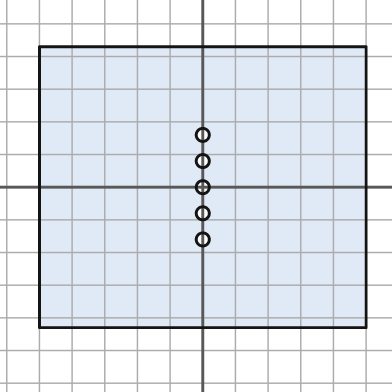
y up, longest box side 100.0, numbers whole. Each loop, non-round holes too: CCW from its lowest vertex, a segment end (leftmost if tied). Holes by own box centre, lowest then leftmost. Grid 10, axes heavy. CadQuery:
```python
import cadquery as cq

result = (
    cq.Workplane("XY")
    .moveTo(-50.0, -43.0)
    .lineTo(50.0, -43.0)
    .lineTo(50.0, 43.0)
    .lineTo(-50.0, 43.0)
    .close()
    .moveTo(0.0, -16.0)
    .circle(2.0)
    .moveTo(0.0, -8.0)
    .circle(2.0)
    .moveTo(0.0, 0.0)
    .circle(2.0)
    .moveTo(0.0, 8.0)
    .circle(2.0)
    .moveTo(0.0, 16.0)
    .circle(2.0)
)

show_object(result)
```